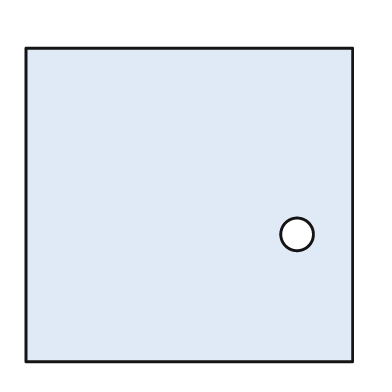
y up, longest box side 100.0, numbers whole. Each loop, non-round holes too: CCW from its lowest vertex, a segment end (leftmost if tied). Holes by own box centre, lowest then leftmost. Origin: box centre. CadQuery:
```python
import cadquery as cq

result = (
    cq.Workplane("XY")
    .moveTo(-50.0, -48.0)
    .lineTo(50.0, -48.0)
    .lineTo(50.0, 48.0)
    .lineTo(-50.0, 48.0)
    .close()
    .moveTo(33.0, -9.0)
    .circle(5.0)
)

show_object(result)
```